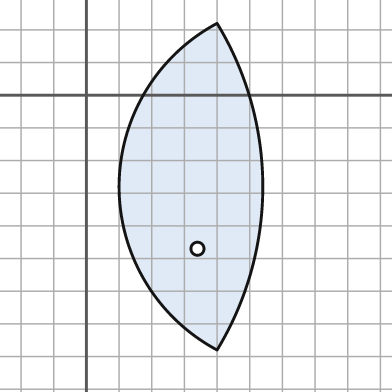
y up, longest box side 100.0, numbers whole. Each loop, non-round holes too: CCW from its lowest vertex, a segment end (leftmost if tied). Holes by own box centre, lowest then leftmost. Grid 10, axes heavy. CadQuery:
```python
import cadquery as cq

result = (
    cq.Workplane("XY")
    .moveTo(40.0, -78.0)
    .threePointArc((54.0, -28.0), (40.0, 22.0))
    .threePointArc((10.0, -28.0), (40.0, -78.0))
    .close()
    .moveTo(34.0, -47.0)
    .circle(2.0)
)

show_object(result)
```